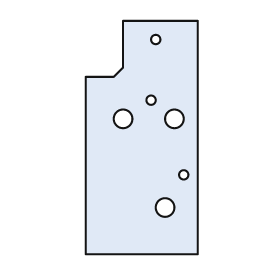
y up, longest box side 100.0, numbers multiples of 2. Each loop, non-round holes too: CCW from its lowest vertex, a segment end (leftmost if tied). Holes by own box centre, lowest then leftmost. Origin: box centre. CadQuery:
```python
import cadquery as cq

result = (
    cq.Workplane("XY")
    .moveTo(-24.0, -50.0)
    .lineTo(24.0, -50.0)
    .lineTo(24.0, 50.0)
    .lineTo(-8.0, 50.0)
    .lineTo(-8.0, 30.0)
    .lineTo(-12.0, 26.0)
    .lineTo(-24.0, 26.0)
    .close()
    .moveTo(10.0, -30.0)
    .circle(4.0)
    .moveTo(18.0, -16.0)
    .circle(2.0)
    .moveTo(-8.0, 8.0)
    .circle(4.0)
    .moveTo(14.0, 8.0)
    .circle(4.0)
    .moveTo(4.0, 16.0)
    .circle(2.0)
    .moveTo(6.0, 42.0)
    .circle(2.0)
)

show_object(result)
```